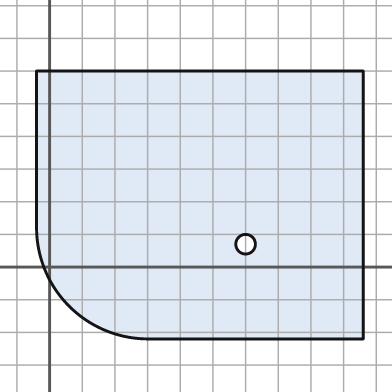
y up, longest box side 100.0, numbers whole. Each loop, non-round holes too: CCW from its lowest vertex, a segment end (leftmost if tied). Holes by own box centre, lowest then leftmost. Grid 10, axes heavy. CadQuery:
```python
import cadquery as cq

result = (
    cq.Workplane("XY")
    .moveTo(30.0, -22.0)
    .lineTo(96.0, -22.0)
    .lineTo(96.0, 60.0)
    .lineTo(-4.0, 60.0)
    .lineTo(-4.0, 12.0)
    .threePointArc((6.0, -12.0), (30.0, -22.0))
    .close()
    .moveTo(60.0, 7.0)
    .circle(3.0)
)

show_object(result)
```